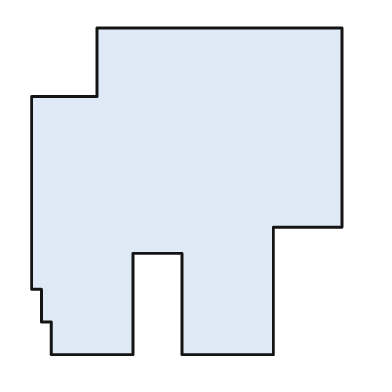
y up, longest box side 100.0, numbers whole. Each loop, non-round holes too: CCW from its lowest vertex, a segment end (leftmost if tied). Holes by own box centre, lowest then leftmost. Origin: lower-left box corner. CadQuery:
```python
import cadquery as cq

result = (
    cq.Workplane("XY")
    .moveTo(6.0, 0.0)
    .lineTo(31.0, 0.0)
    .lineTo(31.0, 31.0)
    .lineTo(46.0, 31.0)
    .lineTo(46.0, 0.0)
    .lineTo(74.0, 0.0)
    .lineTo(74.0, 39.0)
    .lineTo(95.0, 39.0)
    .lineTo(95.0, 100.0)
    .lineTo(20.0, 100.0)
    .lineTo(20.0, 79.0)
    .lineTo(0.0, 79.0)
    .lineTo(0.0, 20.0)
    .lineTo(3.0, 20.0)
    .lineTo(3.0, 10.0)
    .lineTo(6.0, 10.0)
    .close()
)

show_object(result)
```